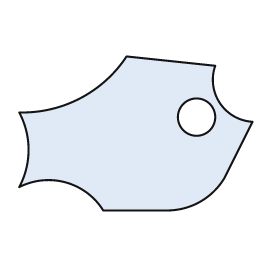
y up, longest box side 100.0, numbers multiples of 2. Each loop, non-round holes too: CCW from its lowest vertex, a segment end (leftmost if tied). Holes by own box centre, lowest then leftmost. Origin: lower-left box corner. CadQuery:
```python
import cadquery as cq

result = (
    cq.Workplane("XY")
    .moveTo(36.0, 0.0)
    .lineTo(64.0, 0.0)
    .threePointArc((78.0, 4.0), (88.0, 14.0))
    .lineTo(100.0, 38.0)
    .threePointArc((86.0, 46.0), (84.0, 62.0))
    .lineTo(46.0, 66.0)
    .threePointArc((26.0, 48.0), (0.0, 42.0))
    .threePointArc((4.0, 26.0), (0.0, 10.0))
    .threePointArc((20.0, 12.0), (36.0, 0.0))
    .close()
    .moveTo(76.0, 40.0)
    .circle(8.0)
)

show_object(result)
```